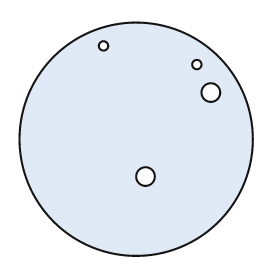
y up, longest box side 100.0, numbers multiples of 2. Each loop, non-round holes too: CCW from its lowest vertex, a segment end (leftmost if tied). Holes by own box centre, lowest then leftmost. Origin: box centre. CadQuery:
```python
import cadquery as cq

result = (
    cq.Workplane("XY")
    .moveTo(0.0, 0.0)
    .circle(50.0)
    .moveTo(4.0, -16.0)
    .circle(4.0)
    .moveTo(32.0, 20.0)
    .circle(4.0)
    .moveTo(26.0, 32.0)
    .circle(2.0)
    .moveTo(-14.0, 40.0)
    .circle(2.0)
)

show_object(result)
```